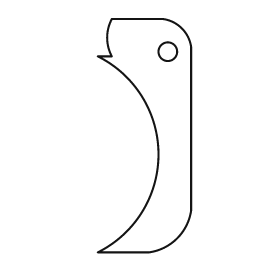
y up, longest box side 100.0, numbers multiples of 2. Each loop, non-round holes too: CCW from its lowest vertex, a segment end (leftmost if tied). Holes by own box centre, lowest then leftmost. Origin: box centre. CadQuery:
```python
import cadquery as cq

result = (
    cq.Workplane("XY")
    .moveTo(-20.0, -50.0)
    .lineTo(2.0, -50.0)
    .threePointArc((14.0, -44.0), (20.0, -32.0))
    .lineTo(20.0, 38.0)
    .threePointArc((16.0, 46.0), (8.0, 50.0))
    .lineTo(-14.0, 50.0)
    .threePointArc((-16.0, 42.0), (-14.0, 34.0))
    .lineTo(-20.0, 34.0)
    .threePointArc((6.0, -8.0), (-20.0, -50.0))
    .close()
    .moveTo(10.0, 36.0)
    .circle(4.0)
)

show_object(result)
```